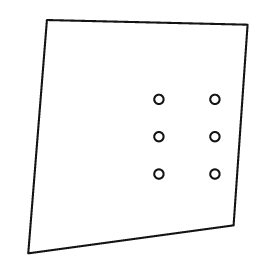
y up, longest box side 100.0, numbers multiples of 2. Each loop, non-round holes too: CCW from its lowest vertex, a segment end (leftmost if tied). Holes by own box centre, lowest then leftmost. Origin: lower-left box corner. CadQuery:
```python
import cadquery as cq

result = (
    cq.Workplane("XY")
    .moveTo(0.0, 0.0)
    .lineTo(88.0, 12.0)
    .lineTo(94.0, 98.0)
    .lineTo(8.0, 100.0)
    .close()
    .moveTo(56.0, 34.0)
    .circle(2.0)
    .moveTo(80.0, 34.0)
    .circle(2.0)
    .moveTo(56.0, 50.0)
    .circle(2.0)
    .moveTo(80.0, 50.0)
    .circle(2.0)
    .moveTo(56.0, 66.0)
    .circle(2.0)
    .moveTo(80.0, 66.0)
    .circle(2.0)
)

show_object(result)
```